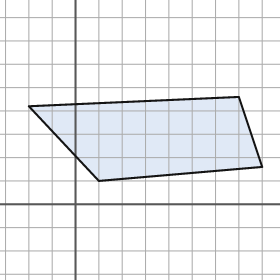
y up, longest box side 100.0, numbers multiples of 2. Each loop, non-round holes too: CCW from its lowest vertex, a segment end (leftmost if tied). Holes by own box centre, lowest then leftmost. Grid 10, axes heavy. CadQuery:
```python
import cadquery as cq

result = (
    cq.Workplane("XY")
    .moveTo(10.0, 10.0)
    .lineTo(80.0, 16.0)
    .lineTo(70.0, 46.0)
    .lineTo(-20.0, 42.0)
    .close()
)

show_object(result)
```